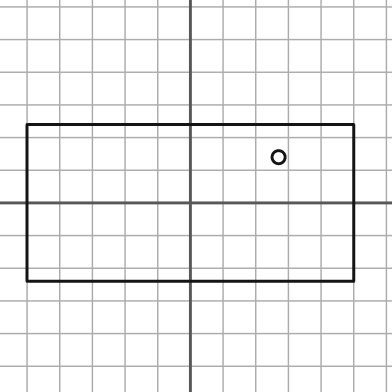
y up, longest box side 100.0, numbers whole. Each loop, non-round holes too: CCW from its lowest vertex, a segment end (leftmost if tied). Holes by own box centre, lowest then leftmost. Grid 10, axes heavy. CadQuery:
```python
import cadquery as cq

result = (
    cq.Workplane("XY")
    .moveTo(-50.0, -24.0)
    .lineTo(50.0, -24.0)
    .lineTo(50.0, 24.0)
    .lineTo(-50.0, 24.0)
    .close()
    .moveTo(27.0, 14.0)
    .circle(2.0)
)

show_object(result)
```